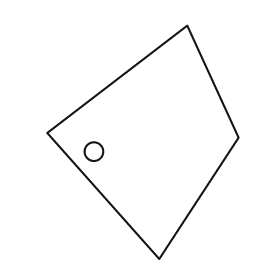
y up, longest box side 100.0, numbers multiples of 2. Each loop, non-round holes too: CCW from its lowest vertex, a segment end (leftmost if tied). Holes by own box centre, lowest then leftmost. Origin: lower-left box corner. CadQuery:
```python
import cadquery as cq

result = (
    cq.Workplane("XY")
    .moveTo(48.0, 0.0)
    .lineTo(82.0, 52.0)
    .lineTo(60.0, 100.0)
    .lineTo(0.0, 54.0)
    .close()
    .moveTo(20.0, 46.0)
    .circle(4.0)
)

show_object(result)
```